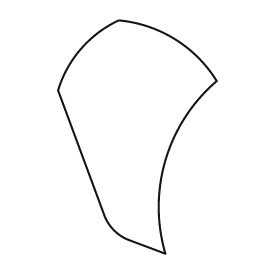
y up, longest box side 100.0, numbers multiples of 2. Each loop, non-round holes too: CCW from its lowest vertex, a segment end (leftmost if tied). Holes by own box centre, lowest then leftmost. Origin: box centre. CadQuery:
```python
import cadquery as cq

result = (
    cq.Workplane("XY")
    .moveTo(12.0, -50.0)
    .threePointArc((12.0, -10.0), (34.0, 24.0))
    .threePointArc((16.0, 42.0), (-8.0, 50.0))
    .threePointArc((-24.0, 38.0), (-34.0, 20.0))
    .lineTo(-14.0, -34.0)
    .threePointArc((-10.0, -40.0), (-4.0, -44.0))
    .close()
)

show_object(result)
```